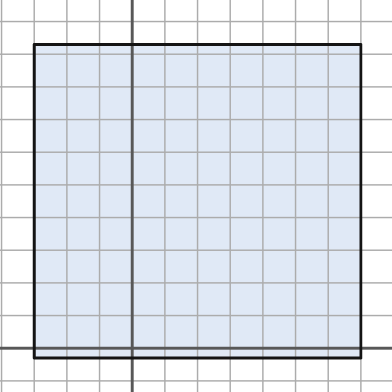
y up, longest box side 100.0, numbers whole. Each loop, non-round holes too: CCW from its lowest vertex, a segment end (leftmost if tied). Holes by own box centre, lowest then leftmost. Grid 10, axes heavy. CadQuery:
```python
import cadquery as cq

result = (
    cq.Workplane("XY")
    .moveTo(-30.0, -3.0)
    .lineTo(70.0, -3.0)
    .lineTo(70.0, 93.0)
    .lineTo(-30.0, 93.0)
    .close()
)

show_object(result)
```